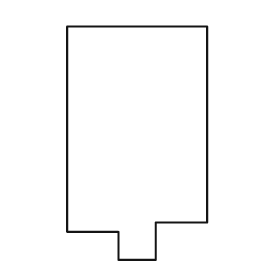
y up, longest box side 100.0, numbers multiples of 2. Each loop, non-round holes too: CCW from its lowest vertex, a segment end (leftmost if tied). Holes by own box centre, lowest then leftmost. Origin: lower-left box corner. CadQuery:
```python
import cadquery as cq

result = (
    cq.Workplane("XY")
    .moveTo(22.0, 0.0)
    .lineTo(38.0, 0.0)
    .lineTo(38.0, 16.0)
    .lineTo(60.0, 16.0)
    .lineTo(60.0, 100.0)
    .lineTo(0.0, 100.0)
    .lineTo(0.0, 12.0)
    .lineTo(22.0, 12.0)
    .close()
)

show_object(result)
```